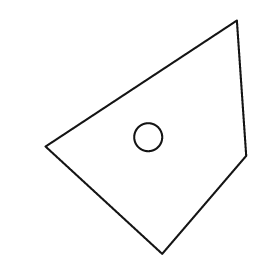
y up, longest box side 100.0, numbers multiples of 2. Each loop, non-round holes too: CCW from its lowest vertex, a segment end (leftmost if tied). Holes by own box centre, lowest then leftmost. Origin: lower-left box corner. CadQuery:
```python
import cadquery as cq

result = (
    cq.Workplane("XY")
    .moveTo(50.0, 0.0)
    .lineTo(86.0, 42.0)
    .lineTo(82.0, 100.0)
    .lineTo(0.0, 46.0)
    .close()
    .moveTo(44.0, 50.0)
    .circle(6.0)
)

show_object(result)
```